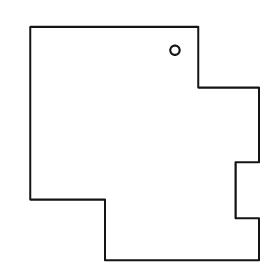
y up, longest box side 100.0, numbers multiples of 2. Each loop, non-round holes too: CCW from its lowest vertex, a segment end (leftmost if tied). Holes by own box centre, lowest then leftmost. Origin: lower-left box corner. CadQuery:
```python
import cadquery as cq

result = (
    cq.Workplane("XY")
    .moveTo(32.0, 0.0)
    .lineTo(98.0, 0.0)
    .lineTo(98.0, 18.0)
    .lineTo(88.0, 18.0)
    .lineTo(88.0, 42.0)
    .lineTo(98.0, 42.0)
    .lineTo(98.0, 74.0)
    .lineTo(72.0, 74.0)
    .lineTo(72.0, 100.0)
    .lineTo(0.0, 100.0)
    .lineTo(0.0, 26.0)
    .lineTo(32.0, 26.0)
    .close()
    .moveTo(62.0, 90.0)
    .circle(2.0)
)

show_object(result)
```